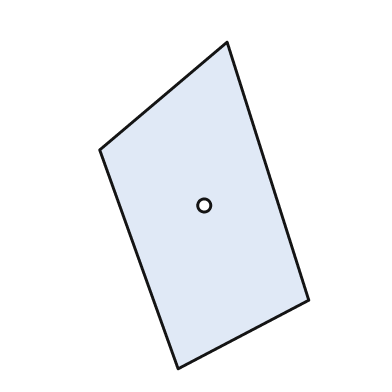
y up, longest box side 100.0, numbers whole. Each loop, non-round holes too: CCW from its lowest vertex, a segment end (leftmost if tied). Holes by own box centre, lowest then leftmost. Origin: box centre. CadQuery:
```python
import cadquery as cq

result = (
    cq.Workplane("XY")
    .moveTo(-8.0, -50.0)
    .lineTo(32.0, -29.0)
    .lineTo(7.0, 50.0)
    .lineTo(-32.0, 17.0)
    .close()
    .moveTo(0.0, 0.0)
    .circle(2.0)
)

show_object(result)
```